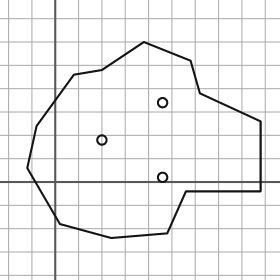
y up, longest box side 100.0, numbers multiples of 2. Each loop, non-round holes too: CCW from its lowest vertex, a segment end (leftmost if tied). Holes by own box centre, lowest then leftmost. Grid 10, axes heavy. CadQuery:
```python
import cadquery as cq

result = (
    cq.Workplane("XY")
    .moveTo(24.0, -24.0)
    .lineTo(48.0, -22.0)
    .lineTo(56.0, -4.0)
    .lineTo(88.0, -4.0)
    .lineTo(88.0, 26.0)
    .lineTo(62.0, 38.0)
    .lineTo(58.0, 52.0)
    .lineTo(38.0, 60.0)
    .lineTo(20.0, 48.0)
    .lineTo(8.0, 46.0)
    .lineTo(-8.0, 24.0)
    .lineTo(-12.0, 6.0)
    .lineTo(2.0, -18.0)
    .close()
    .moveTo(46.0, 2.0)
    .circle(2.0)
    .moveTo(20.0, 18.0)
    .circle(2.0)
    .moveTo(46.0, 34.0)
    .circle(2.0)
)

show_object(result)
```